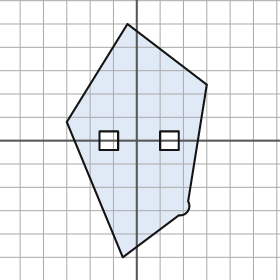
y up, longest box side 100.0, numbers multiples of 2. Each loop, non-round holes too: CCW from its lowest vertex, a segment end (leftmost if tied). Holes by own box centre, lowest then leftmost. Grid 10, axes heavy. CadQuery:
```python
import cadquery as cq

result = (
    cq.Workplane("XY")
    .moveTo(-6.0, -50.0)
    .lineTo(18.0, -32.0)
    .threePointArc((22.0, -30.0), (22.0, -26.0))
    .lineTo(30.0, 24.0)
    .lineTo(-4.0, 50.0)
    .lineTo(-30.0, 8.0)
    .close()
    .moveTo(-16.0, -4.0)
    .lineTo(-8.0, -4.0)
    .lineTo(-8.0, 4.0)
    .lineTo(-16.0, 4.0)
    .close()
    .moveTo(10.0, -4.0)
    .lineTo(18.0, -4.0)
    .lineTo(18.0, 4.0)
    .lineTo(10.0, 4.0)
    .close()
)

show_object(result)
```